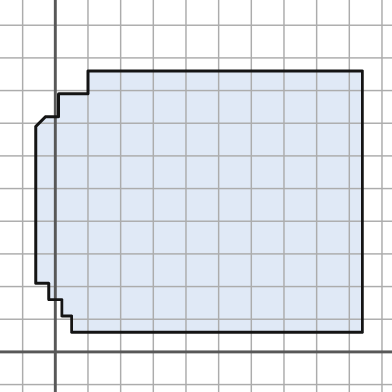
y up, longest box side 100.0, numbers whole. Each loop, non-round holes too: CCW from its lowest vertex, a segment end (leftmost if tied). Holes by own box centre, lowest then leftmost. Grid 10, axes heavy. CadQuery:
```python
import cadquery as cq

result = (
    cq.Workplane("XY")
    .moveTo(5.0, 6.0)
    .lineTo(94.0, 6.0)
    .lineTo(94.0, 86.0)
    .lineTo(10.0, 86.0)
    .lineTo(10.0, 79.0)
    .lineTo(1.0, 79.0)
    .lineTo(1.0, 72.0)
    .lineTo(-3.0, 72.0)
    .lineTo(-6.0, 69.0)
    .lineTo(-6.0, 21.0)
    .lineTo(-2.0, 21.0)
    .lineTo(-2.0, 16.0)
    .lineTo(2.0, 16.0)
    .lineTo(2.0, 11.0)
    .lineTo(5.0, 11.0)
    .close()
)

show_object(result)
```